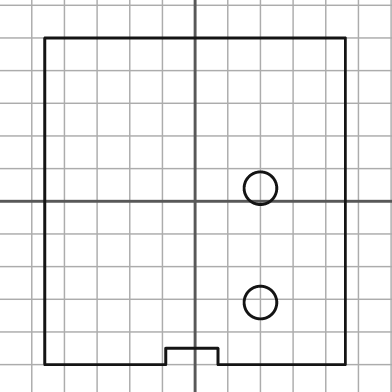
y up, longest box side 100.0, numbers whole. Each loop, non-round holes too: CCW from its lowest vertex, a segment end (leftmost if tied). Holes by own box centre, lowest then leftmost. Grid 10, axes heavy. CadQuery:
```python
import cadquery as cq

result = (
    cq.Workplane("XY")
    .moveTo(-46.0, -50.0)
    .lineTo(-9.0, -50.0)
    .lineTo(-9.0, -45.0)
    .lineTo(7.0, -45.0)
    .lineTo(7.0, -50.0)
    .lineTo(46.0, -50.0)
    .lineTo(46.0, 50.0)
    .lineTo(-46.0, 50.0)
    .close()
    .moveTo(20.0, -31.0)
    .circle(5.0)
    .moveTo(20.0, 4.0)
    .circle(5.0)
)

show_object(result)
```